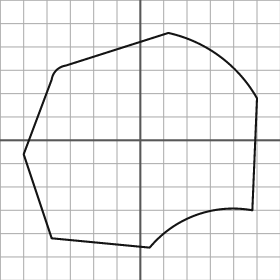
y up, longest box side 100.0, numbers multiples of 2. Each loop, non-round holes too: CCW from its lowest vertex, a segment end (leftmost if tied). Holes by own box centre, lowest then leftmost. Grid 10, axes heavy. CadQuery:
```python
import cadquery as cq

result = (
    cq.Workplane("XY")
    .moveTo(4.0, -46.0)
    .threePointArc((24.0, -32.0), (48.0, -30.0))
    .lineTo(50.0, 18.0)
    .threePointArc((34.0, 36.0), (12.0, 46.0))
    .lineTo(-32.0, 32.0)
    .threePointArc((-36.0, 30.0), (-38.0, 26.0))
    .lineTo(-50.0, -6.0)
    .lineTo(-38.0, -42.0)
    .close()
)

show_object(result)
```